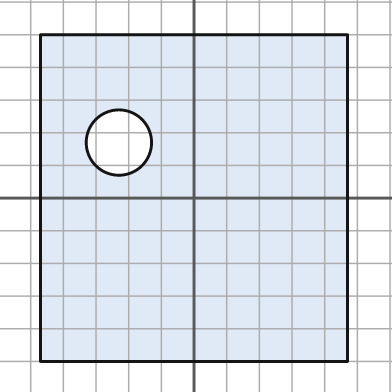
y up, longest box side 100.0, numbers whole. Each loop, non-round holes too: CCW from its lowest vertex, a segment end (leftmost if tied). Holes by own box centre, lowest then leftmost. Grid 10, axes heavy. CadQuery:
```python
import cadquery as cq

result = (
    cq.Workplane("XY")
    .moveTo(-47.0, -50.0)
    .lineTo(47.0, -50.0)
    .lineTo(47.0, 50.0)
    .lineTo(-47.0, 50.0)
    .close()
    .moveTo(-23.0, 17.0)
    .circle(10.0)
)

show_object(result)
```